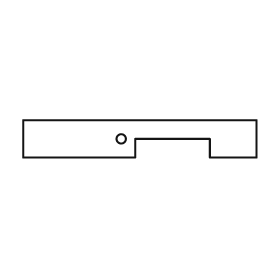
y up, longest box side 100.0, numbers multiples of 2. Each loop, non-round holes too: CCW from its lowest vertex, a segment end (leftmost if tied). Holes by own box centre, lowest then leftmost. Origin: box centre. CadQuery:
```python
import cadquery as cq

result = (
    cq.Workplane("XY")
    .moveTo(-50.0, -8.0)
    .lineTo(-2.0, -8.0)
    .lineTo(-2.0, 0.0)
    .lineTo(30.0, 0.0)
    .lineTo(30.0, -8.0)
    .lineTo(50.0, -8.0)
    .lineTo(50.0, 8.0)
    .lineTo(-50.0, 8.0)
    .close()
    .moveTo(-8.0, 0.0)
    .circle(2.0)
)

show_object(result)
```